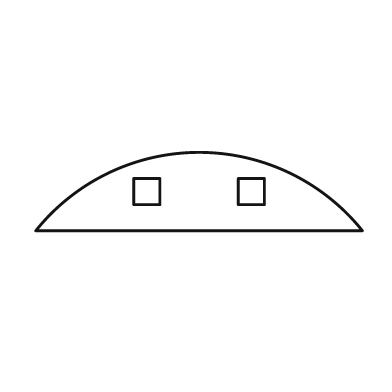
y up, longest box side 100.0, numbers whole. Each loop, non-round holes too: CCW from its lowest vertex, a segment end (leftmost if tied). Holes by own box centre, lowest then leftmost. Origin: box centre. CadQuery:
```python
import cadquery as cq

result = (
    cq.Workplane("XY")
    .moveTo(-50.0, -12.0)
    .lineTo(50.0, -12.0)
    .threePointArc((0.0, 12.0), (-50.0, -12.0))
    .close()
    .moveTo(-20.0, -4.0)
    .lineTo(-12.0, -4.0)
    .lineTo(-12.0, 4.0)
    .lineTo(-20.0, 4.0)
    .close()
    .moveTo(12.0, -4.0)
    .lineTo(20.0, -4.0)
    .lineTo(20.0, 4.0)
    .lineTo(12.0, 4.0)
    .close()
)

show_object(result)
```